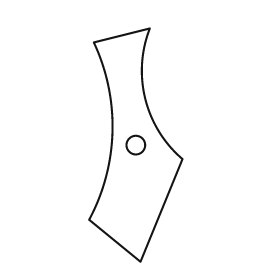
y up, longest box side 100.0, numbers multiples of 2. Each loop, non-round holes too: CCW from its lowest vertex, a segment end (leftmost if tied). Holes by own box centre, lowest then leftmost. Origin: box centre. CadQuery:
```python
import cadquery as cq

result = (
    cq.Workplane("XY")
    .moveTo(2.0, -50.0)
    .lineTo(20.0, -6.0)
    .threePointArc((4.0, 20.0), (6.0, 50.0))
    .lineTo(-18.0, 44.0)
    .threePointArc((-10.0, 6.0), (-20.0, -32.0))
    .close()
    .moveTo(0.0, 0.0)
    .circle(4.0)
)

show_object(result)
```